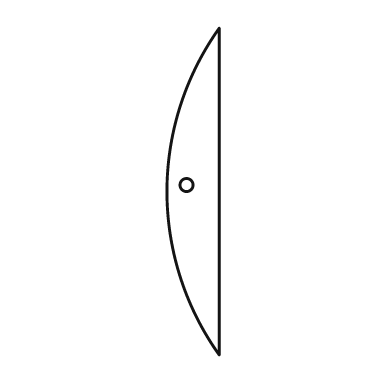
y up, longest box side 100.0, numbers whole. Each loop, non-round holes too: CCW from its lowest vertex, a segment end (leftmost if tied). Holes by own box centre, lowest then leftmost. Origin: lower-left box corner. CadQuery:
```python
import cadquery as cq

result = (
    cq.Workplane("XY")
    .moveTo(16.0, 0.0)
    .lineTo(16.0, 100.0)
    .threePointArc((0.0, 50.0), (16.0, 0.0))
    .close()
    .moveTo(6.0, 52.0)
    .circle(2.0)
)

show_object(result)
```